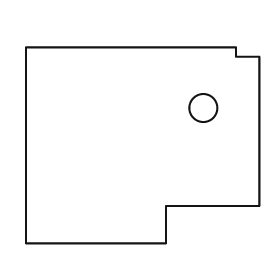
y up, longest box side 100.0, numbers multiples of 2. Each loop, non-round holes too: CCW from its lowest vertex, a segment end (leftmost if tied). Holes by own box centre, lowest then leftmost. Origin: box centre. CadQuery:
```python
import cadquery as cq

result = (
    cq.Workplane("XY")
    .moveTo(-50.0, -42.0)
    .lineTo(10.0, -42.0)
    .lineTo(10.0, -26.0)
    .lineTo(50.0, -26.0)
    .lineTo(50.0, 38.0)
    .lineTo(40.0, 38.0)
    .lineTo(40.0, 42.0)
    .lineTo(-50.0, 42.0)
    .close()
    .moveTo(26.0, 16.0)
    .circle(6.0)
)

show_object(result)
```